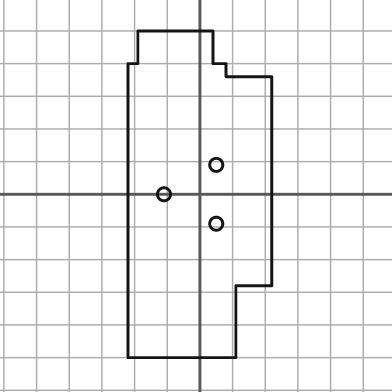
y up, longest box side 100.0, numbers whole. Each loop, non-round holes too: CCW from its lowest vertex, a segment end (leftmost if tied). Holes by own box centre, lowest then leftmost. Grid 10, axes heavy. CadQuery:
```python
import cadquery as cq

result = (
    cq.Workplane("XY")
    .moveTo(-22.0, -50.0)
    .lineTo(11.0, -50.0)
    .lineTo(11.0, -28.0)
    .lineTo(22.0, -28.0)
    .lineTo(22.0, 36.0)
    .lineTo(8.0, 36.0)
    .lineTo(8.0, 40.0)
    .lineTo(4.0, 40.0)
    .lineTo(4.0, 50.0)
    .lineTo(-19.0, 50.0)
    .lineTo(-19.0, 40.0)
    .lineTo(-22.0, 40.0)
    .close()
    .moveTo(5.0, -9.0)
    .circle(2.0)
    .moveTo(-11.0, 0.0)
    .circle(2.0)
    .moveTo(5.0, 9.0)
    .circle(2.0)
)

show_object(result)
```